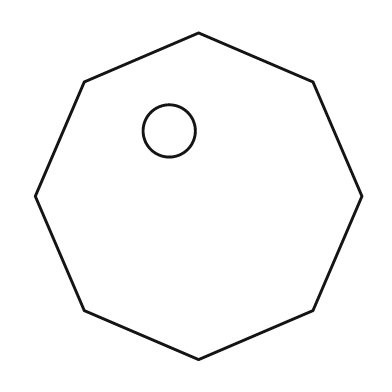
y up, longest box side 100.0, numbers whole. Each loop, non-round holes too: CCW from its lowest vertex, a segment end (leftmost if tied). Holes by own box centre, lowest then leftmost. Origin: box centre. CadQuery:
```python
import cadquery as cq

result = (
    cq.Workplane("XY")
    .moveTo(0.0, -50.0)
    .lineTo(35.0, -35.0)
    .lineTo(50.0, 0.0)
    .lineTo(35.0, 35.0)
    .lineTo(0.0, 50.0)
    .lineTo(-35.0, 35.0)
    .lineTo(-50.0, 0.0)
    .lineTo(-35.0, -35.0)
    .close()
    .moveTo(-9.0, 20.0)
    .circle(8.0)
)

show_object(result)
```